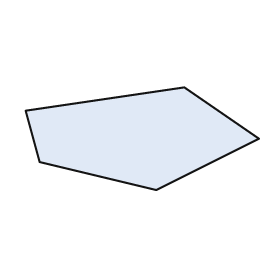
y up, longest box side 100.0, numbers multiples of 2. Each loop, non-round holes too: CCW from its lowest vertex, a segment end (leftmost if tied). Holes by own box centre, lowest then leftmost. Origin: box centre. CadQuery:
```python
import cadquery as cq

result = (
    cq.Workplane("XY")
    .moveTo(6.0, -22.0)
    .lineTo(50.0, 0.0)
    .lineTo(18.0, 22.0)
    .lineTo(-50.0, 12.0)
    .lineTo(-44.0, -10.0)
    .close()
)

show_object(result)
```